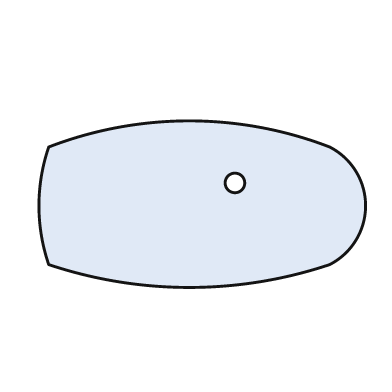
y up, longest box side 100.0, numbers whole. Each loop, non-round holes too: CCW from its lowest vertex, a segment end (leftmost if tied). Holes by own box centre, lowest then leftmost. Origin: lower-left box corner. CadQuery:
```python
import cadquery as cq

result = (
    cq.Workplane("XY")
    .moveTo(3.0, 7.0)
    .threePointArc((46.0, 0.0), (89.0, 7.0))
    .threePointArc((100.0, 25.0), (89.0, 43.0))
    .threePointArc((46.0, 51.0), (3.0, 43.0))
    .threePointArc((0.0, 25.0), (3.0, 7.0))
    .close()
    .moveTo(60.0, 32.0)
    .circle(3.0)
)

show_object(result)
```